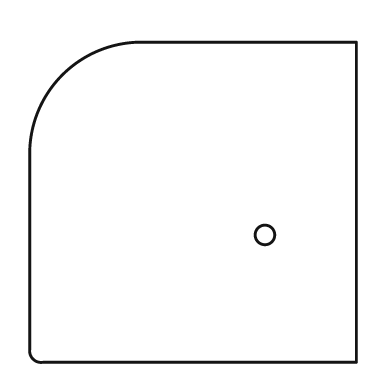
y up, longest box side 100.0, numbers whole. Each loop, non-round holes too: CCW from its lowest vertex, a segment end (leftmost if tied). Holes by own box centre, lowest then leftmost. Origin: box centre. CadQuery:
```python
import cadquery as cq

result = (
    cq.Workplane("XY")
    .moveTo(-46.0, -49.0)
    .lineTo(50.0, -49.0)
    .lineTo(50.0, 49.0)
    .lineTo(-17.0, 49.0)
    .threePointArc((-40.0, 39.0), (-50.0, 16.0))
    .lineTo(-50.0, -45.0)
    .threePointArc((-49.0, -48.0), (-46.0, -49.0))
    .close()
    .moveTo(22.0, -10.0)
    .circle(3.0)
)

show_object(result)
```